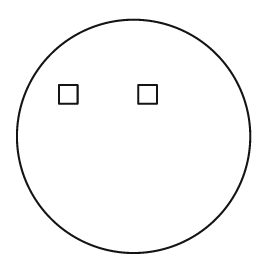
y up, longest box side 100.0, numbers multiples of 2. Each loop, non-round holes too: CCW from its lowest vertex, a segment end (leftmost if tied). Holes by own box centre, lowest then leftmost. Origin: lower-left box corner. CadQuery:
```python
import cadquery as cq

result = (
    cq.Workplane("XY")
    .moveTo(50.0, 50.0)
    .circle(50.0)
    .moveTo(18.0, 64.0)
    .lineTo(26.0, 64.0)
    .lineTo(26.0, 72.0)
    .lineTo(18.0, 72.0)
    .close()
    .moveTo(52.0, 64.0)
    .lineTo(60.0, 64.0)
    .lineTo(60.0, 72.0)
    .lineTo(52.0, 72.0)
    .close()
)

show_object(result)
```